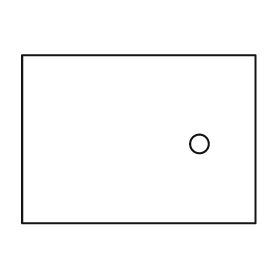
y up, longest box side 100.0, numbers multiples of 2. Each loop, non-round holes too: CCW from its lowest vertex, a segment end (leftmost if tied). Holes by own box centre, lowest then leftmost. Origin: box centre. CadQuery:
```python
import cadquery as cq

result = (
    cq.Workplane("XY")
    .moveTo(-50.0, -36.0)
    .lineTo(50.0, -36.0)
    .lineTo(50.0, 36.0)
    .lineTo(-50.0, 36.0)
    .close()
    .moveTo(26.0, -2.0)
    .circle(4.0)
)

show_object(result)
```